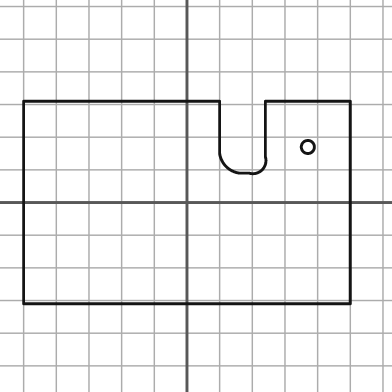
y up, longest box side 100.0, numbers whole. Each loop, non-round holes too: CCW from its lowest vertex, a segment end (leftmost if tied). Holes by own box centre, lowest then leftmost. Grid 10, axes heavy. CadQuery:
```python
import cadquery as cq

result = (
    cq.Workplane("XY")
    .moveTo(-50.0, -31.0)
    .lineTo(50.0, -31.0)
    .lineTo(50.0, 31.0)
    .lineTo(24.0, 31.0)
    .lineTo(24.0, 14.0)
    .threePointArc((23.0, 10.0), (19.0, 9.0))
    .lineTo(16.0, 9.0)
    .threePointArc((12.0, 11.0), (10.0, 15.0))
    .lineTo(10.0, 31.0)
    .lineTo(-50.0, 31.0)
    .close()
    .moveTo(37.0, 17.0)
    .circle(2.0)
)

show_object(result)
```